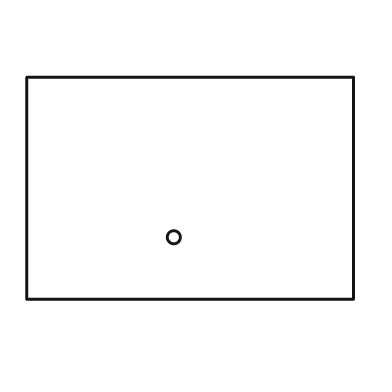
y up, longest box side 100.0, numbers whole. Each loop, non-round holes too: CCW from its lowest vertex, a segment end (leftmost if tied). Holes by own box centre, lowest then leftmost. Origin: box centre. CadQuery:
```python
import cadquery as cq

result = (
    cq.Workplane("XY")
    .moveTo(-50.0, -34.0)
    .lineTo(50.0, -34.0)
    .lineTo(50.0, 34.0)
    .lineTo(-50.0, 34.0)
    .close()
    .moveTo(-5.0, -15.0)
    .circle(2.0)
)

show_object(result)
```